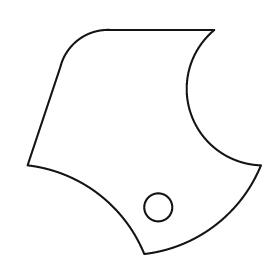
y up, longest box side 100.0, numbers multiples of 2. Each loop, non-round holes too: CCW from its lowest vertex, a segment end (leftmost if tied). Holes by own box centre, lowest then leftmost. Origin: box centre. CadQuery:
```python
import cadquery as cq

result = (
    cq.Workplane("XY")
    .moveTo(0.0, -48.0)
    .threePointArc((30.0, -36.0), (50.0, -10.0))
    .threePointArc((20.0, 12.0), (30.0, 48.0))
    .lineTo(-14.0, 48.0)
    .threePointArc((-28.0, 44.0), (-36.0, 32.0))
    .lineTo(-50.0, -10.0)
    .threePointArc((-20.0, -22.0), (0.0, -48.0))
    .close()
    .moveTo(6.0, -28.0)
    .circle(6.0)
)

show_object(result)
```